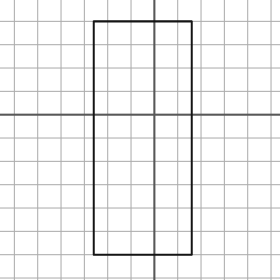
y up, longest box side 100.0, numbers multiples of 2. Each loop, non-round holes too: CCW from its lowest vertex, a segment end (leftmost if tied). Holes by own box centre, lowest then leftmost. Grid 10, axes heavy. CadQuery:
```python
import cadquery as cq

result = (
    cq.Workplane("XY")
    .moveTo(-26.0, -60.0)
    .lineTo(16.0, -60.0)
    .lineTo(16.0, 40.0)
    .lineTo(-26.0, 40.0)
    .close()
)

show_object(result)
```